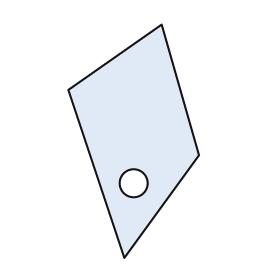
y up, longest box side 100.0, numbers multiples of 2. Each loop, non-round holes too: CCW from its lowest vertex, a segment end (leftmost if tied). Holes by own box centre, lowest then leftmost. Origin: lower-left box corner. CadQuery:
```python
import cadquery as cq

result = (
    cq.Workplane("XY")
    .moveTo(24.0, 0.0)
    .lineTo(56.0, 44.0)
    .lineTo(40.0, 100.0)
    .lineTo(0.0, 72.0)
    .close()
    .moveTo(28.0, 32.0)
    .circle(6.0)
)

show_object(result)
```